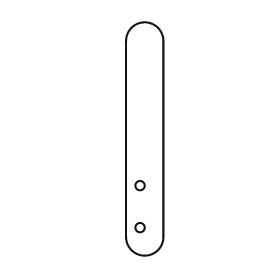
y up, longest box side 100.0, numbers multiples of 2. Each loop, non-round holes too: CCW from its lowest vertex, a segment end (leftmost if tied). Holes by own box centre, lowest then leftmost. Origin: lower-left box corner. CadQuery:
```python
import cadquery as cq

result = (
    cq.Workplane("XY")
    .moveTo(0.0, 8.0)
    .threePointArc((8.0, 0.0), (16.0, 8.0))
    .lineTo(16.0, 92.0)
    .threePointArc((8.0, 100.0), (0.0, 92.0))
    .close()
    .moveTo(6.0, 12.0)
    .circle(2.0)
    .moveTo(6.0, 30.0)
    .circle(2.0)
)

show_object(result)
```